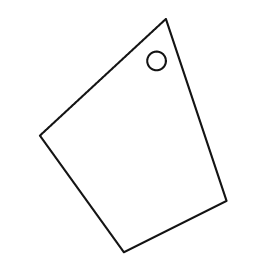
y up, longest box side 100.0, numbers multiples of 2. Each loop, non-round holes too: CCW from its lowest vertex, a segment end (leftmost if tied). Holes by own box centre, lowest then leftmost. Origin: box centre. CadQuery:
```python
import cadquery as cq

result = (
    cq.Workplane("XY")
    .moveTo(-4.0, -50.0)
    .lineTo(40.0, -28.0)
    .lineTo(14.0, 50.0)
    .lineTo(-40.0, 0.0)
    .close()
    .moveTo(10.0, 32.0)
    .circle(4.0)
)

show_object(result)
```